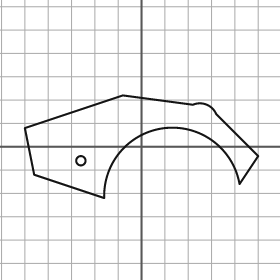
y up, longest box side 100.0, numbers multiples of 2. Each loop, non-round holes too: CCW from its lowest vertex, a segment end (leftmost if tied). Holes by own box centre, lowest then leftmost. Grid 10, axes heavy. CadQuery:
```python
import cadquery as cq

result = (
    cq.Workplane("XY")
    .moveTo(-16.0, -22.0)
    .threePointArc((10.0, 8.0), (42.0, -16.0))
    .lineTo(50.0, -4.0)
    .lineTo(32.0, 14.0)
    .threePointArc((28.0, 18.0), (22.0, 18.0))
    .lineTo(-8.0, 22.0)
    .lineTo(-50.0, 8.0)
    .lineTo(-46.0, -12.0)
    .close()
    .moveTo(-26.0, -6.0)
    .circle(2.0)
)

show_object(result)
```